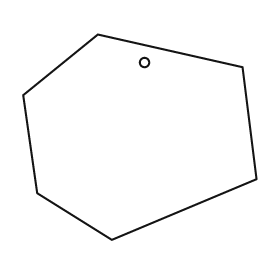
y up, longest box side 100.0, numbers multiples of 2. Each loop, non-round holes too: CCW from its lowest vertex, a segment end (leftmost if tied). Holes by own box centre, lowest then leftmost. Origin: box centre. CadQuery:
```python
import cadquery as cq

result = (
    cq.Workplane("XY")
    .moveTo(-12.0, -44.0)
    .lineTo(50.0, -18.0)
    .lineTo(44.0, 30.0)
    .lineTo(-18.0, 44.0)
    .lineTo(-50.0, 18.0)
    .lineTo(-44.0, -24.0)
    .close()
    .moveTo(2.0, 32.0)
    .circle(2.0)
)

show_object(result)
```